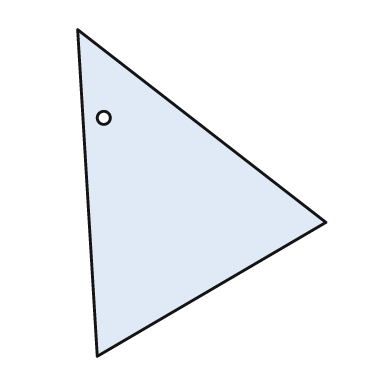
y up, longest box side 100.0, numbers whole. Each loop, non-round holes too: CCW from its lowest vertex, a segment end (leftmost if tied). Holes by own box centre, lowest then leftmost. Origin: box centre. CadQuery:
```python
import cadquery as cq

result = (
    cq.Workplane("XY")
    .moveTo(-32.0, -50.0)
    .lineTo(38.0, -9.0)
    .lineTo(-38.0, 50.0)
    .close()
    .moveTo(-30.0, 23.0)
    .circle(2.0)
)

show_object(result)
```